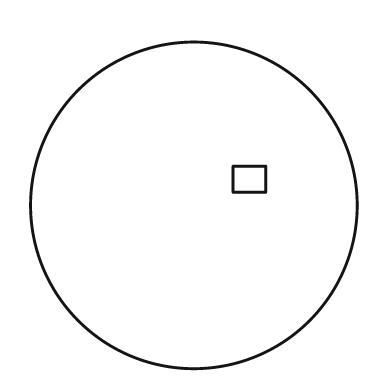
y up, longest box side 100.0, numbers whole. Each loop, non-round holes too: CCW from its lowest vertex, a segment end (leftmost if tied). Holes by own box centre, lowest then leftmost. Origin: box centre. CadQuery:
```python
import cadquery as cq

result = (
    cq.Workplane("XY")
    .moveTo(0.0, 0.0)
    .circle(50.0)
    .moveTo(12.0, 4.0)
    .lineTo(22.0, 4.0)
    .lineTo(22.0, 12.0)
    .lineTo(12.0, 12.0)
    .close()
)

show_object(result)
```